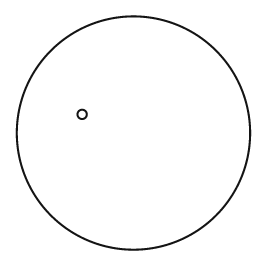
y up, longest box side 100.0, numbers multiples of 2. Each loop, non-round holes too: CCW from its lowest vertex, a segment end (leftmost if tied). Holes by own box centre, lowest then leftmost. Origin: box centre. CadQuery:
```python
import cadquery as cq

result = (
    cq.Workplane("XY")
    .moveTo(0.0, 0.0)
    .circle(50.0)
    .moveTo(-22.0, 8.0)
    .circle(2.0)
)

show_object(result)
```